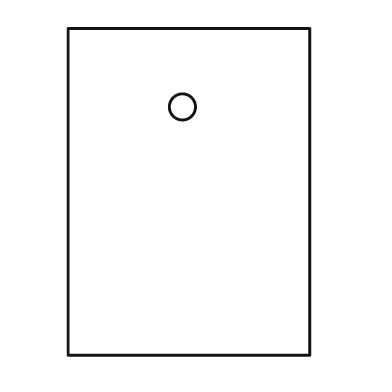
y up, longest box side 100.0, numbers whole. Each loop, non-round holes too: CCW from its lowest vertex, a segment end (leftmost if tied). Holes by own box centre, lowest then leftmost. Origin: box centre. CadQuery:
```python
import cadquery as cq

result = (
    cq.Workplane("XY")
    .moveTo(-37.0, -50.0)
    .lineTo(37.0, -50.0)
    .lineTo(37.0, 50.0)
    .lineTo(-37.0, 50.0)
    .close()
    .moveTo(-2.0, 26.0)
    .circle(4.0)
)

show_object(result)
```